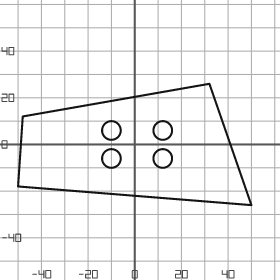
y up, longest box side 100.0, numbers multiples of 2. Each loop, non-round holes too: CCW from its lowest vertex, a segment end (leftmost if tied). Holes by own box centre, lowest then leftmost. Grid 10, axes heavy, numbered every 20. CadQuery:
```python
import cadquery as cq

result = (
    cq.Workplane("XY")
    .moveTo(50.0, -26.0)
    .lineTo(32.0, 26.0)
    .lineTo(-48.0, 12.0)
    .lineTo(-50.0, -18.0)
    .close()
    .moveTo(-10.0, -6.0)
    .circle(4.0)
    .moveTo(12.0, -6.0)
    .circle(4.0)
    .moveTo(-10.0, 6.0)
    .circle(4.0)
    .moveTo(12.0, 6.0)
    .circle(4.0)
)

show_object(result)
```